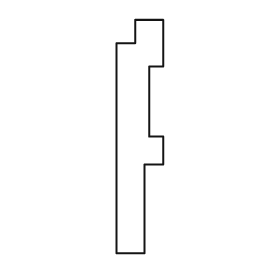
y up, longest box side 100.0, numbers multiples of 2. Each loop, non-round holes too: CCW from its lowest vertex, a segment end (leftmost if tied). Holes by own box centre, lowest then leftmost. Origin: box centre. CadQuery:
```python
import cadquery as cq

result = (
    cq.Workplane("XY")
    .moveTo(-10.0, -50.0)
    .lineTo(2.0, -50.0)
    .lineTo(2.0, -12.0)
    .lineTo(10.0, -12.0)
    .lineTo(10.0, 0.0)
    .lineTo(4.0, 0.0)
    .lineTo(4.0, 30.0)
    .lineTo(10.0, 30.0)
    .lineTo(10.0, 50.0)
    .lineTo(-2.0, 50.0)
    .lineTo(-2.0, 40.0)
    .lineTo(-10.0, 40.0)
    .close()
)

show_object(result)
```